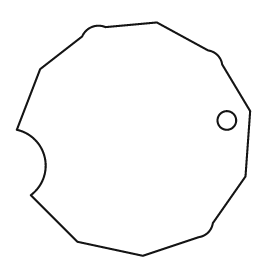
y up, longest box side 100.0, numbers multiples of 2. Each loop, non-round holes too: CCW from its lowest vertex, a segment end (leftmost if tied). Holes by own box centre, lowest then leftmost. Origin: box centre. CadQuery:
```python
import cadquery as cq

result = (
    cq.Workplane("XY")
    .moveTo(4.0, -50.0)
    .lineTo(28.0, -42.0)
    .threePointArc((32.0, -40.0), (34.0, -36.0))
    .lineTo(48.0, -16.0)
    .lineTo(50.0, 12.0)
    .lineTo(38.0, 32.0)
    .threePointArc((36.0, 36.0), (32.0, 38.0))
    .lineTo(10.0, 50.0)
    .lineTo(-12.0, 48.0)
    .threePointArc((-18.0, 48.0), (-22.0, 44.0))
    .lineTo(-40.0, 30.0)
    .lineTo(-50.0, 4.0)
    .threePointArc((-38.0, -8.0), (-44.0, -24.0))
    .lineTo(-24.0, -44.0)
    .close()
    .moveTo(40.0, 8.0)
    .circle(4.0)
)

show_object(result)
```